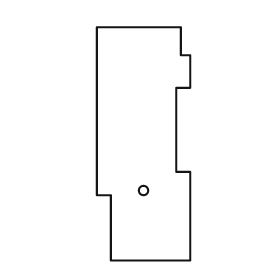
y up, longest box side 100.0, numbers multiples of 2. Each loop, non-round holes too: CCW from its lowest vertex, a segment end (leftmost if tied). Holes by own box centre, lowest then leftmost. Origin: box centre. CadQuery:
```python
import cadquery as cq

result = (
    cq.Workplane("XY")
    .moveTo(-14.0, -50.0)
    .lineTo(20.0, -50.0)
    .lineTo(20.0, -12.0)
    .lineTo(14.0, -12.0)
    .lineTo(14.0, 24.0)
    .lineTo(20.0, 24.0)
    .lineTo(20.0, 38.0)
    .lineTo(16.0, 38.0)
    .lineTo(16.0, 50.0)
    .lineTo(-20.0, 50.0)
    .lineTo(-20.0, -22.0)
    .lineTo(-14.0, -22.0)
    .close()
    .moveTo(0.0, -20.0)
    .circle(2.0)
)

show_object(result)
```